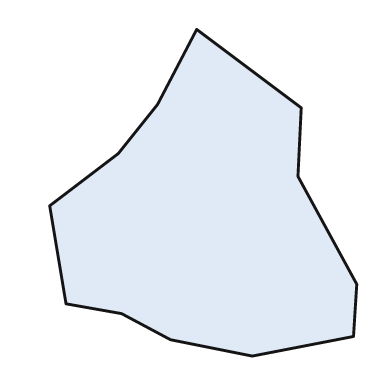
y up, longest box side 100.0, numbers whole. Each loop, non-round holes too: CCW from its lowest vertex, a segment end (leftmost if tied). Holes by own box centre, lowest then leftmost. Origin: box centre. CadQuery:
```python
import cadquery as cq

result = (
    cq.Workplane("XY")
    .moveTo(15.0, -50.0)
    .lineTo(46.0, -44.0)
    .lineTo(47.0, -28.0)
    .lineTo(29.0, 5.0)
    .lineTo(30.0, 26.0)
    .lineTo(-2.0, 50.0)
    .lineTo(-14.0, 27.0)
    .lineTo(-26.0, 12.0)
    .lineTo(-47.0, -4.0)
    .lineTo(-42.0, -34.0)
    .lineTo(-25.0, -37.0)
    .lineTo(-10.0, -45.0)
    .close()
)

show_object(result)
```